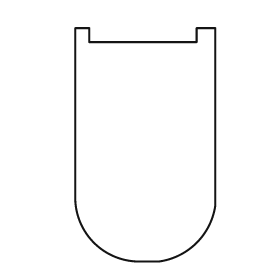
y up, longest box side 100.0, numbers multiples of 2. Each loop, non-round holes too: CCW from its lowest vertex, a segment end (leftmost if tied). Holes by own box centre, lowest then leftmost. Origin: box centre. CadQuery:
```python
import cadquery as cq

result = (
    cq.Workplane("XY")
    .moveTo(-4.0, -50.0)
    .lineTo(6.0, -50.0)
    .threePointArc((22.0, -42.0), (30.0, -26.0))
    .lineTo(30.0, 50.0)
    .lineTo(22.0, 50.0)
    .lineTo(22.0, 44.0)
    .lineTo(-24.0, 44.0)
    .lineTo(-24.0, 50.0)
    .lineTo(-30.0, 50.0)
    .lineTo(-30.0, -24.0)
    .threePointArc((-22.0, -42.0), (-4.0, -50.0))
    .close()
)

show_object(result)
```